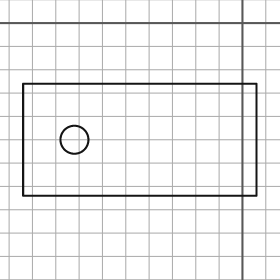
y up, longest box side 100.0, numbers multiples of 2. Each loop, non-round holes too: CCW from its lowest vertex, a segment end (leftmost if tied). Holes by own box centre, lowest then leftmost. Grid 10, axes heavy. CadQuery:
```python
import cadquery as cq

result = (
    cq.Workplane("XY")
    .moveTo(-94.0, -74.0)
    .lineTo(6.0, -74.0)
    .lineTo(6.0, -26.0)
    .lineTo(-94.0, -26.0)
    .close()
    .moveTo(-72.0, -50.0)
    .circle(6.0)
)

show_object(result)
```